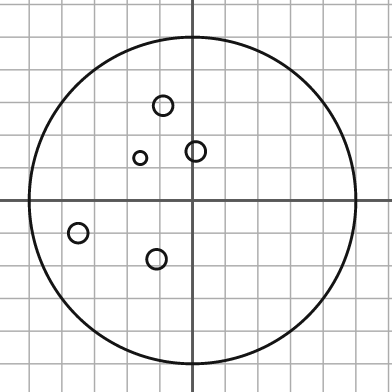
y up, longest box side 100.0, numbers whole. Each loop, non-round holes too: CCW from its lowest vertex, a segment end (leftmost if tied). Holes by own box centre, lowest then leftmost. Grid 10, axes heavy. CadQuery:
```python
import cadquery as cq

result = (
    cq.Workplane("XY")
    .moveTo(0.0, 0.0)
    .circle(50.0)
    .moveTo(-11.0, -18.0)
    .circle(3.0)
    .moveTo(-35.0, -10.0)
    .circle(3.0)
    .moveTo(-16.0, 13.0)
    .circle(2.0)
    .moveTo(1.0, 15.0)
    .circle(3.0)
    .moveTo(-9.0, 29.0)
    .circle(3.0)
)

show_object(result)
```